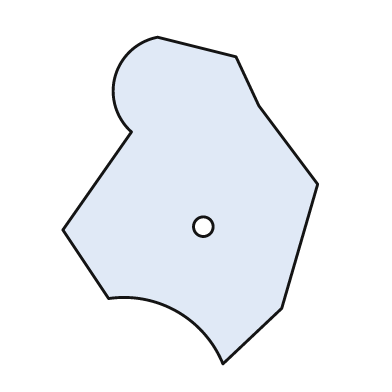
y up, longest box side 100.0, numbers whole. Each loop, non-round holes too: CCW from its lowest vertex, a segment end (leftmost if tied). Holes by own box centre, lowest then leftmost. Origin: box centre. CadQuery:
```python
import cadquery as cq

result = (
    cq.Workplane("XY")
    .moveTo(10.0, -50.0)
    .lineTo(28.0, -33.0)
    .lineTo(39.0, 5.0)
    .lineTo(21.0, 29.0)
    .lineTo(14.0, 44.0)
    .lineTo(-10.0, 50.0)
    .threePointArc((-23.0, 38.0), (-18.0, 21.0))
    .lineTo(-39.0, -9.0)
    .lineTo(-25.0, -30.0)
    .threePointArc((-4.0, -34.0), (10.0, -50.0))
    .close()
    .moveTo(4.0, -8.0)
    .circle(3.0)
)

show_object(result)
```